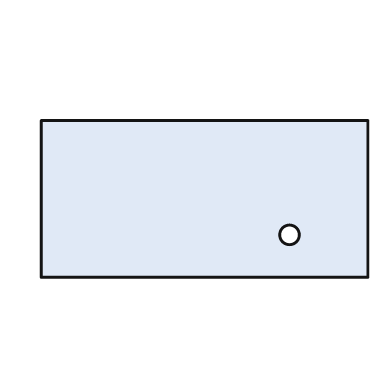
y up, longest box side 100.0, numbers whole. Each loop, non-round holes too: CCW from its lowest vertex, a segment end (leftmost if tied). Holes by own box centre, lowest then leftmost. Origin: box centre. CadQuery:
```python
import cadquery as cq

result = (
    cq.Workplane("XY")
    .moveTo(-50.0, -24.0)
    .lineTo(50.0, -24.0)
    .lineTo(50.0, 24.0)
    .lineTo(-50.0, 24.0)
    .close()
    .moveTo(26.0, -11.0)
    .circle(3.0)
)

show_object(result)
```